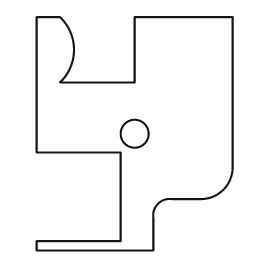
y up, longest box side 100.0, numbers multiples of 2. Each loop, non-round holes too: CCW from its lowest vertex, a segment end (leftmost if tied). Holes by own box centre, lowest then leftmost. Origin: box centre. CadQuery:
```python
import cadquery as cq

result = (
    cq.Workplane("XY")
    .moveTo(-42.0, -50.0)
    .lineTo(8.0, -50.0)
    .lineTo(8.0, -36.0)
    .threePointArc((10.0, -30.0), (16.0, -28.0))
    .lineTo(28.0, -28.0)
    .threePointArc((38.0, -24.0), (42.0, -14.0))
    .lineTo(42.0, 50.0)
    .lineTo(0.0, 50.0)
    .lineTo(0.0, 22.0)
    .lineTo(-32.0, 22.0)
    .threePointArc((-26.0, 36.0), (-32.0, 50.0))
    .lineTo(-42.0, 50.0)
    .lineTo(-42.0, -8.0)
    .lineTo(-6.0, -8.0)
    .lineTo(-6.0, -46.0)
    .lineTo(-42.0, -46.0)
    .close()
    .moveTo(0.0, 0.0)
    .circle(6.0)
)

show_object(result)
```